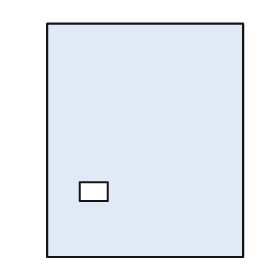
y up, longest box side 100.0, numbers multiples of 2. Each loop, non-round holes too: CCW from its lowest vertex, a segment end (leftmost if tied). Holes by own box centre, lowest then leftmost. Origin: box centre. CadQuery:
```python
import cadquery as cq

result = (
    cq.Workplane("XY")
    .moveTo(-42.0, -50.0)
    .lineTo(42.0, -50.0)
    .lineTo(42.0, 50.0)
    .lineTo(-42.0, 50.0)
    .close()
    .moveTo(-28.0, -26.0)
    .lineTo(-16.0, -26.0)
    .lineTo(-16.0, -18.0)
    .lineTo(-28.0, -18.0)
    .close()
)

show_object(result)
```